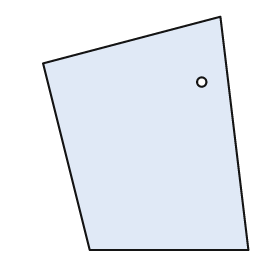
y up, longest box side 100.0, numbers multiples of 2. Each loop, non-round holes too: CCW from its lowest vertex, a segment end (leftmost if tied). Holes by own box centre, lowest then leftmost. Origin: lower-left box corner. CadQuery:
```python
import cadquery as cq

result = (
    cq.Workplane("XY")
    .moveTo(20.0, 0.0)
    .lineTo(88.0, 0.0)
    .lineTo(76.0, 100.0)
    .lineTo(0.0, 80.0)
    .close()
    .moveTo(68.0, 72.0)
    .circle(2.0)
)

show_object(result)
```